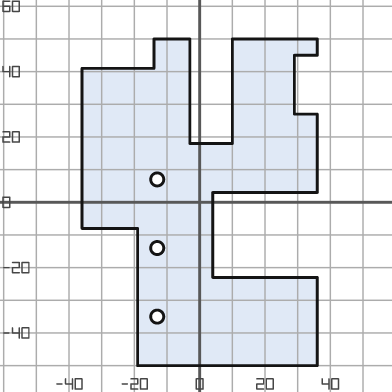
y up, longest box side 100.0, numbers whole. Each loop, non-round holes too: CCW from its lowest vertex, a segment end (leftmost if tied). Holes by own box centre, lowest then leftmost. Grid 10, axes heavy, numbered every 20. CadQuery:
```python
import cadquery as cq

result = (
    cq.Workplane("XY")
    .moveTo(-19.0, -50.0)
    .lineTo(36.0, -50.0)
    .lineTo(36.0, -23.0)
    .lineTo(4.0, -23.0)
    .lineTo(4.0, 3.0)
    .lineTo(36.0, 3.0)
    .lineTo(36.0, 27.0)
    .lineTo(29.0, 27.0)
    .lineTo(29.0, 45.0)
    .lineTo(36.0, 45.0)
    .lineTo(36.0, 50.0)
    .lineTo(10.0, 50.0)
    .lineTo(10.0, 18.0)
    .lineTo(-3.0, 18.0)
    .lineTo(-3.0, 50.0)
    .lineTo(-14.0, 50.0)
    .lineTo(-14.0, 41.0)
    .lineTo(-36.0, 41.0)
    .lineTo(-36.0, -8.0)
    .lineTo(-19.0, -8.0)
    .close()
    .moveTo(-13.0, -35.0)
    .circle(2.0)
    .moveTo(-13.0, -14.0)
    .circle(2.0)
    .moveTo(-13.0, 7.0)
    .circle(2.0)
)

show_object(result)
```